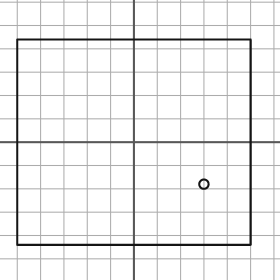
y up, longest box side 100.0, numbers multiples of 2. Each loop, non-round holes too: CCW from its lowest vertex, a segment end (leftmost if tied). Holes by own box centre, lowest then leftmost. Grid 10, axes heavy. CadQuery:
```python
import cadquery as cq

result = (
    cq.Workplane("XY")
    .moveTo(-50.0, -44.0)
    .lineTo(50.0, -44.0)
    .lineTo(50.0, 44.0)
    .lineTo(-50.0, 44.0)
    .close()
    .moveTo(30.0, -18.0)
    .circle(2.0)
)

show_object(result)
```